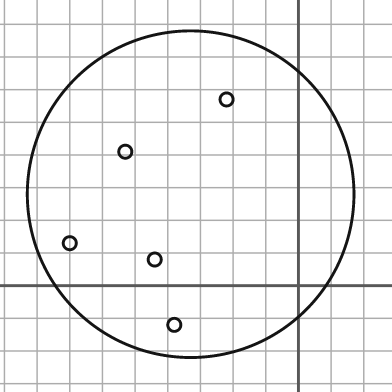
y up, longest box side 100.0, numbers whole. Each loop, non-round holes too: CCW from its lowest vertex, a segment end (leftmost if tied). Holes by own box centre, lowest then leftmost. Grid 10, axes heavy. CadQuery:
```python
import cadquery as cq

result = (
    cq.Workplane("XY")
    .moveTo(-33.0, 28.0)
    .circle(50.0)
    .moveTo(-38.0, -12.0)
    .circle(2.0)
    .moveTo(-44.0, 8.0)
    .circle(2.0)
    .moveTo(-70.0, 13.0)
    .circle(2.0)
    .moveTo(-53.0, 41.0)
    .circle(2.0)
    .moveTo(-22.0, 57.0)
    .circle(2.0)
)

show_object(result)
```